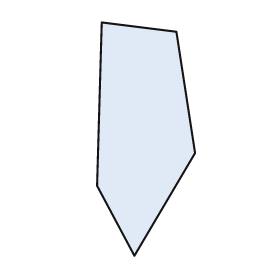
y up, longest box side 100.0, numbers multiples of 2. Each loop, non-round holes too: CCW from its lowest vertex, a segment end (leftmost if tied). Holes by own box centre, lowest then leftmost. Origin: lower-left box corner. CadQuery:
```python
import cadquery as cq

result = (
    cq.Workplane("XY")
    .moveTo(16.0, 0.0)
    .lineTo(42.0, 44.0)
    .lineTo(34.0, 96.0)
    .lineTo(2.0, 100.0)
    .lineTo(0.0, 30.0)
    .close()
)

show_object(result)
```